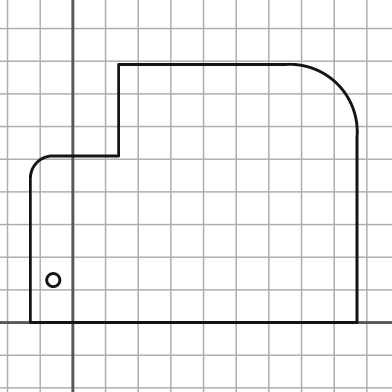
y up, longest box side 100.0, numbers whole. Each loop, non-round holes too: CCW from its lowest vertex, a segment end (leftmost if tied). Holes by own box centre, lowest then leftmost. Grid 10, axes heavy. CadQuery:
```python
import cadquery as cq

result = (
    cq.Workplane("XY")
    .moveTo(-13.0, 0.0)
    .lineTo(87.0, 0.0)
    .lineTo(87.0, 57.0)
    .threePointArc((81.0, 73.0), (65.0, 79.0))
    .lineTo(14.0, 79.0)
    .lineTo(14.0, 51.0)
    .lineTo(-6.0, 51.0)
    .threePointArc((-11.0, 49.0), (-13.0, 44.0))
    .close()
    .moveTo(-6.0, 13.0)
    .circle(2.0)
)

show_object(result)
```